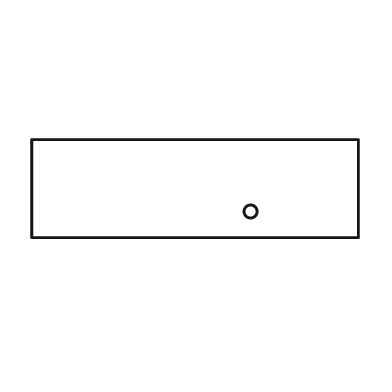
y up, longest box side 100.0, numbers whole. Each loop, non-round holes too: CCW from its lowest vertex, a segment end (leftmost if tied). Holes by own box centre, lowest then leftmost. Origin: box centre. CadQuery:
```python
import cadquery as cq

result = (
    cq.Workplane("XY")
    .moveTo(-50.0, -15.0)
    .lineTo(50.0, -15.0)
    .lineTo(50.0, 15.0)
    .lineTo(-50.0, 15.0)
    .close()
    .moveTo(17.0, -7.0)
    .circle(2.0)
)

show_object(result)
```